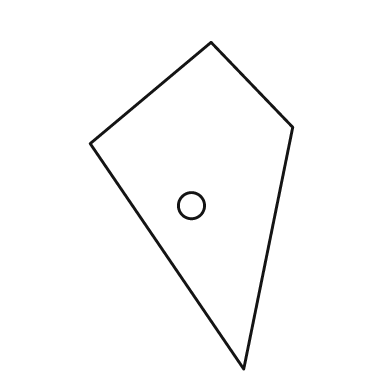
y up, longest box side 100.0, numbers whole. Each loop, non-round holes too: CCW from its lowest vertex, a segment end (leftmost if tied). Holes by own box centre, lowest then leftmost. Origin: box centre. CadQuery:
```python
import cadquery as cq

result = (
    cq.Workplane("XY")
    .moveTo(16.0, -50.0)
    .lineTo(31.0, 24.0)
    .lineTo(6.0, 50.0)
    .lineTo(-31.0, 19.0)
    .close()
    .moveTo(0.0, 0.0)
    .circle(4.0)
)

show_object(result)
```